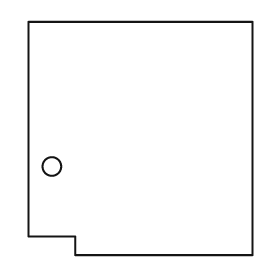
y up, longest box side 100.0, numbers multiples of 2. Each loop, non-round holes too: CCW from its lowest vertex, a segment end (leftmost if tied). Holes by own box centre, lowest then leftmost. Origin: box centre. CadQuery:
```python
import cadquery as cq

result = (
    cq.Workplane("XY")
    .moveTo(-28.0, -50.0)
    .lineTo(48.0, -50.0)
    .lineTo(48.0, 50.0)
    .lineTo(-48.0, 50.0)
    .lineTo(-48.0, -42.0)
    .lineTo(-28.0, -42.0)
    .close()
    .moveTo(-38.0, -12.0)
    .circle(4.0)
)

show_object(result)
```